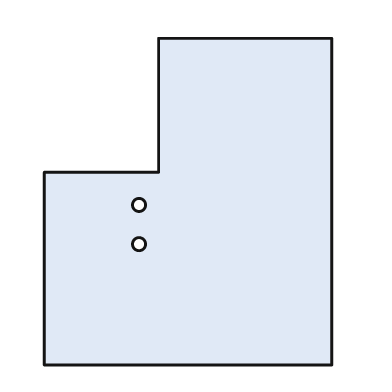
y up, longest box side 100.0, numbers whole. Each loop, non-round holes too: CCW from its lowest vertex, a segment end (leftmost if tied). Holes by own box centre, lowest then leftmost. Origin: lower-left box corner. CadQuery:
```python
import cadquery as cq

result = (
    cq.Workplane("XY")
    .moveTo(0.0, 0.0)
    .lineTo(88.0, 0.0)
    .lineTo(88.0, 100.0)
    .lineTo(35.0, 100.0)
    .lineTo(35.0, 59.0)
    .lineTo(0.0, 59.0)
    .close()
    .moveTo(29.0, 37.0)
    .circle(2.0)
    .moveTo(29.0, 49.0)
    .circle(2.0)
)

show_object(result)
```